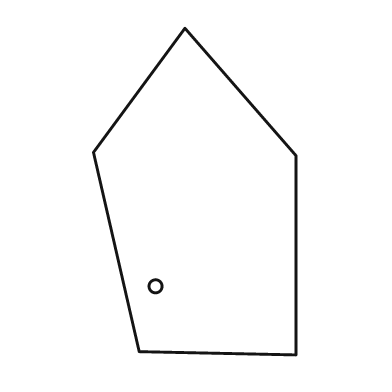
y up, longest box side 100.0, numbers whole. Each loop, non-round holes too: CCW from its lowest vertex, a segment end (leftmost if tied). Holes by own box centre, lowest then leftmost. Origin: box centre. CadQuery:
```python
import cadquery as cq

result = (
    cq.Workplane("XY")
    .moveTo(31.0, -50.0)
    .lineTo(31.0, 11.0)
    .lineTo(-3.0, 50.0)
    .lineTo(-31.0, 12.0)
    .lineTo(-17.0, -49.0)
    .close()
    .moveTo(-12.0, -29.0)
    .circle(2.0)
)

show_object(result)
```